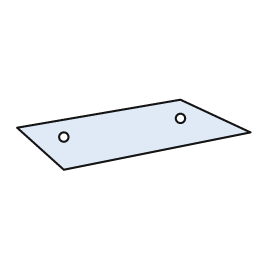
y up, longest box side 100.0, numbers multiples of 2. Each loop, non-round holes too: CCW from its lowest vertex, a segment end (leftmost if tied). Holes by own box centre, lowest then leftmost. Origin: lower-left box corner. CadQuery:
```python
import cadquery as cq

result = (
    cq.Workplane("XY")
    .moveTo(20.0, 0.0)
    .lineTo(100.0, 16.0)
    .lineTo(70.0, 30.0)
    .lineTo(0.0, 18.0)
    .close()
    .moveTo(20.0, 14.0)
    .circle(2.0)
    .moveTo(70.0, 22.0)
    .circle(2.0)
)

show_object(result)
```